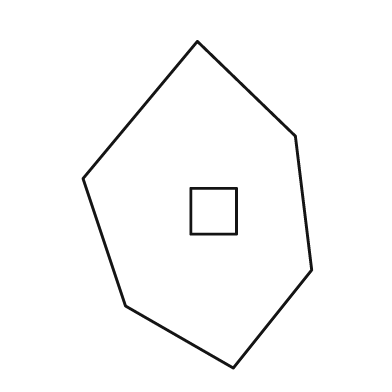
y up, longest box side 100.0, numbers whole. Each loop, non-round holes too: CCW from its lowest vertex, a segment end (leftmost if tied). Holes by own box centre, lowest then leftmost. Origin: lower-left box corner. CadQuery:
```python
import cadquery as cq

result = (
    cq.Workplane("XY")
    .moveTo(46.0, 0.0)
    .lineTo(70.0, 30.0)
    .lineTo(65.0, 71.0)
    .lineTo(35.0, 100.0)
    .lineTo(0.0, 58.0)
    .lineTo(13.0, 19.0)
    .close()
    .moveTo(33.0, 41.0)
    .lineTo(47.0, 41.0)
    .lineTo(47.0, 55.0)
    .lineTo(33.0, 55.0)
    .close()
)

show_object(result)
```